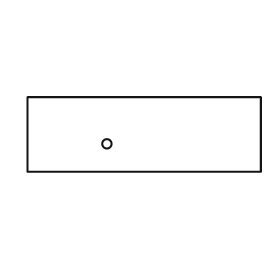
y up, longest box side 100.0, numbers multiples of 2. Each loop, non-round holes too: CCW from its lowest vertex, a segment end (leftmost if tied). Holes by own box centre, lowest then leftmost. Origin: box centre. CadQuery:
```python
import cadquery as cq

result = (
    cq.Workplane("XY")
    .moveTo(-50.0, -16.0)
    .lineTo(50.0, -16.0)
    .lineTo(50.0, 16.0)
    .lineTo(-50.0, 16.0)
    .close()
    .moveTo(-16.0, -4.0)
    .circle(2.0)
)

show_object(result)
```